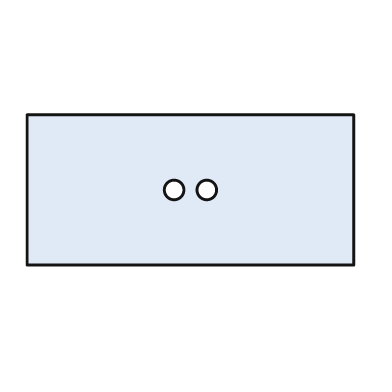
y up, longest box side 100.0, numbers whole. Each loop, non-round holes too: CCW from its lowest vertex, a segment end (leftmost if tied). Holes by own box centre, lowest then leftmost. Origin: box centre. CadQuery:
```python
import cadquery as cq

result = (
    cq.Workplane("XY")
    .moveTo(-50.0, -23.0)
    .lineTo(50.0, -23.0)
    .lineTo(50.0, 23.0)
    .lineTo(-50.0, 23.0)
    .close()
    .moveTo(-5.0, 0.0)
    .circle(3.0)
    .moveTo(5.0, 0.0)
    .circle(3.0)
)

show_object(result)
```